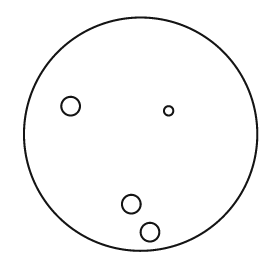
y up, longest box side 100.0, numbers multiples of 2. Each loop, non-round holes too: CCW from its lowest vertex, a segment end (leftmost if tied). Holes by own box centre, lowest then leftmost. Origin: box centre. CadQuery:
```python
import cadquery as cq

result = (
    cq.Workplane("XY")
    .moveTo(0.0, 0.0)
    .circle(50.0)
    .moveTo(4.0, -42.0)
    .circle(4.0)
    .moveTo(-4.0, -30.0)
    .circle(4.0)
    .moveTo(12.0, 10.0)
    .circle(2.0)
    .moveTo(-30.0, 12.0)
    .circle(4.0)
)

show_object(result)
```